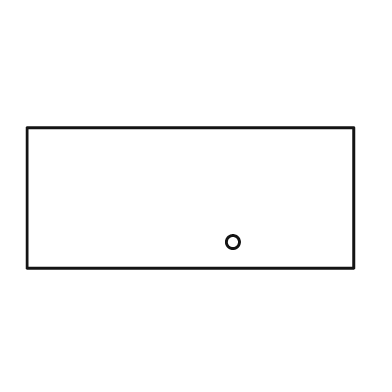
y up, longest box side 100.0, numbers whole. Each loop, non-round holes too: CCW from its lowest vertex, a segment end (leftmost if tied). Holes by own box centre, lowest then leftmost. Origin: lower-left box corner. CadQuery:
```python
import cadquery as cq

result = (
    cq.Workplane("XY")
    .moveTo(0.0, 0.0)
    .lineTo(100.0, 0.0)
    .lineTo(100.0, 43.0)
    .lineTo(0.0, 43.0)
    .close()
    .moveTo(63.0, 8.0)
    .circle(2.0)
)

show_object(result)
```